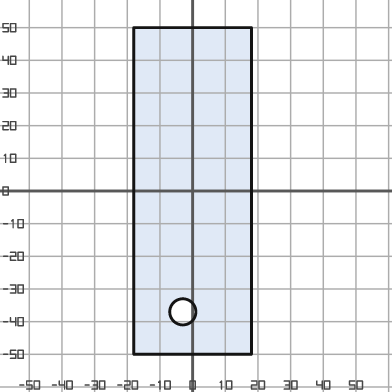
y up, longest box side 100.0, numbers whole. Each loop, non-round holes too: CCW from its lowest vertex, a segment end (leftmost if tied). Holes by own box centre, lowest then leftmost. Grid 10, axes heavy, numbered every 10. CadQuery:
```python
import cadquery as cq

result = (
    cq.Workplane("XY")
    .moveTo(-18.0, -50.0)
    .lineTo(18.0, -50.0)
    .lineTo(18.0, 50.0)
    .lineTo(-18.0, 50.0)
    .close()
    .moveTo(-3.0, -37.0)
    .circle(4.0)
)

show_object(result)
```